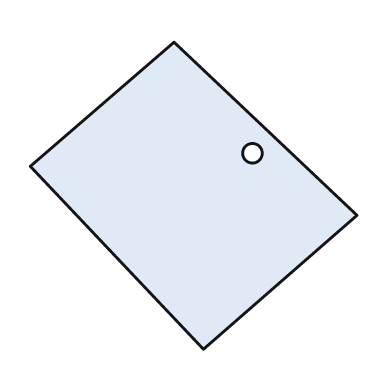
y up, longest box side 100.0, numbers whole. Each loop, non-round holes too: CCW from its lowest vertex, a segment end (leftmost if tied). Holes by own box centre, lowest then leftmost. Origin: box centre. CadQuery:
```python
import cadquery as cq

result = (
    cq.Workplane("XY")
    .moveTo(3.0, -47.0)
    .lineTo(50.0, -6.0)
    .lineTo(-6.0, 47.0)
    .lineTo(-50.0, 9.0)
    .close()
    .moveTo(18.0, 13.0)
    .circle(3.0)
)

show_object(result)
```